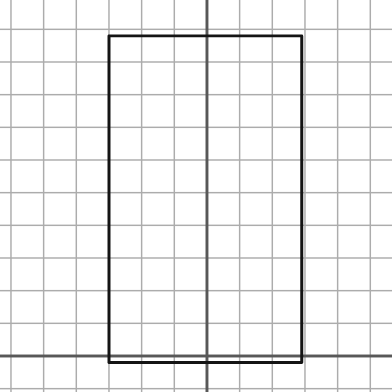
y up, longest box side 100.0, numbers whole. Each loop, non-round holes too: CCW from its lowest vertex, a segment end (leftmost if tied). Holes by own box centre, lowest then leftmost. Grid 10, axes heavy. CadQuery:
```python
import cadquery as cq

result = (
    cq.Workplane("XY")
    .moveTo(-30.0, -2.0)
    .lineTo(29.0, -2.0)
    .lineTo(29.0, 98.0)
    .lineTo(-30.0, 98.0)
    .close()
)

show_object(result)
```